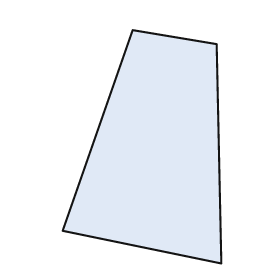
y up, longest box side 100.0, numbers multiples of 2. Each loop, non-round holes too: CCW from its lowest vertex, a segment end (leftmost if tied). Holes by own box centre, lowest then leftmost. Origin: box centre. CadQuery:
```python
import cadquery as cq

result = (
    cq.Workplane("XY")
    .moveTo(34.0, -50.0)
    .lineTo(32.0, 44.0)
    .lineTo(-4.0, 50.0)
    .lineTo(-34.0, -36.0)
    .close()
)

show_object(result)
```